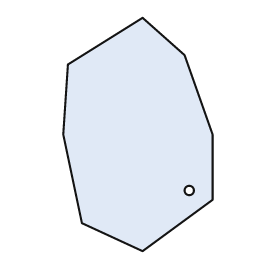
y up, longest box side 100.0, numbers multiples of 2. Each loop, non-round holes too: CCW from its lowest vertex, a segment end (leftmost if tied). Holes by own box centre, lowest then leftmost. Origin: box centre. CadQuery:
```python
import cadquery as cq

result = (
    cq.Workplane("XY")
    .moveTo(2.0, -50.0)
    .lineTo(32.0, -28.0)
    .lineTo(32.0, 0.0)
    .lineTo(20.0, 34.0)
    .lineTo(2.0, 50.0)
    .lineTo(-30.0, 30.0)
    .lineTo(-32.0, 0.0)
    .lineTo(-24.0, -38.0)
    .close()
    .moveTo(22.0, -24.0)
    .circle(2.0)
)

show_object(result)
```